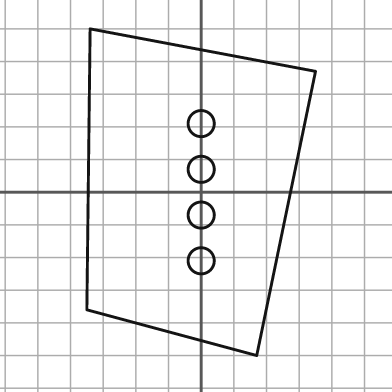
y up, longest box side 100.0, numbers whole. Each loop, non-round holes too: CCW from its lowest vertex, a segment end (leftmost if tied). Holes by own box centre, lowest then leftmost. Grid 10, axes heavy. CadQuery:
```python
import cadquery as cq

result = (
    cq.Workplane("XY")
    .moveTo(17.0, -50.0)
    .lineTo(35.0, 37.0)
    .lineTo(-34.0, 50.0)
    .lineTo(-35.0, -36.0)
    .close()
    .moveTo(0.0, -21.0)
    .circle(4.0)
    .moveTo(0.0, -7.0)
    .circle(4.0)
    .moveTo(0.0, 7.0)
    .circle(4.0)
    .moveTo(0.0, 21.0)
    .circle(4.0)
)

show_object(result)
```